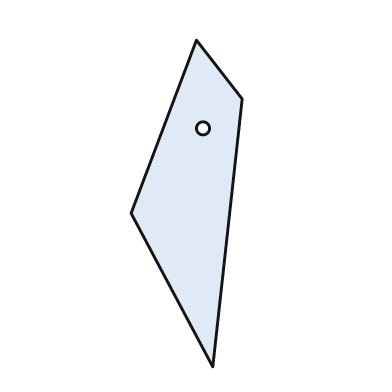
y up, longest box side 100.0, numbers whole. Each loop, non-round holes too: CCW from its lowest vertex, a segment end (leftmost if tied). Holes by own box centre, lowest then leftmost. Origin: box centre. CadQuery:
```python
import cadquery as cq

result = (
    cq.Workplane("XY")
    .moveTo(8.0, -50.0)
    .lineTo(17.0, 32.0)
    .lineTo(3.0, 50.0)
    .lineTo(-17.0, -3.0)
    .close()
    .moveTo(5.0, 23.0)
    .circle(2.0)
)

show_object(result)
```